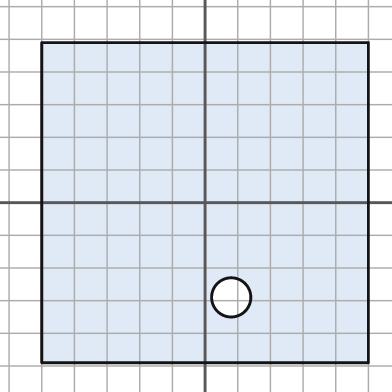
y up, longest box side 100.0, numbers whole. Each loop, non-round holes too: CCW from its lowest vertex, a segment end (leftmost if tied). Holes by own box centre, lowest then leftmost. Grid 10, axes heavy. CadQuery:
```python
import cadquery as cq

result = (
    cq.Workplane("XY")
    .moveTo(-50.0, -49.0)
    .lineTo(50.0, -49.0)
    .lineTo(50.0, 49.0)
    .lineTo(-50.0, 49.0)
    .close()
    .moveTo(8.0, -29.0)
    .circle(6.0)
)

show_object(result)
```